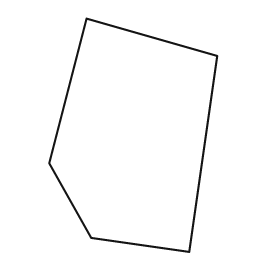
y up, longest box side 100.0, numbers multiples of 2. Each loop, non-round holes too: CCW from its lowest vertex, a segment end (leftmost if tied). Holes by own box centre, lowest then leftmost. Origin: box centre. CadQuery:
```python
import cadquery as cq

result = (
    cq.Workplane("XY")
    .moveTo(24.0, -50.0)
    .lineTo(36.0, 34.0)
    .lineTo(-20.0, 50.0)
    .lineTo(-36.0, -12.0)
    .lineTo(-18.0, -44.0)
    .close()
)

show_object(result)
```